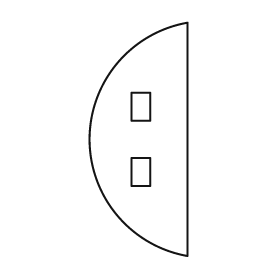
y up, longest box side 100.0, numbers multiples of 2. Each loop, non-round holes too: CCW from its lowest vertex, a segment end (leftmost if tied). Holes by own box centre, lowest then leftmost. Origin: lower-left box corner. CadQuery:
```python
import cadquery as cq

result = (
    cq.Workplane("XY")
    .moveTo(42.0, 0.0)
    .lineTo(42.0, 100.0)
    .threePointArc((0.0, 50.0), (42.0, 0.0))
    .close()
    .moveTo(18.0, 30.0)
    .lineTo(26.0, 30.0)
    .lineTo(26.0, 42.0)
    .lineTo(18.0, 42.0)
    .close()
    .moveTo(18.0, 58.0)
    .lineTo(26.0, 58.0)
    .lineTo(26.0, 70.0)
    .lineTo(18.0, 70.0)
    .close()
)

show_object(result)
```